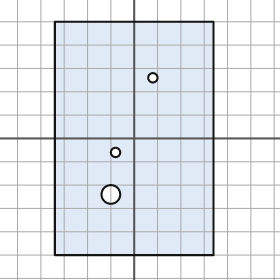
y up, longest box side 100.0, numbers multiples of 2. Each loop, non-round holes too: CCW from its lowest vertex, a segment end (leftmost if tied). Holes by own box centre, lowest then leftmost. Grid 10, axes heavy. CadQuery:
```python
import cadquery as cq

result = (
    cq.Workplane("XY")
    .moveTo(-34.0, -50.0)
    .lineTo(34.0, -50.0)
    .lineTo(34.0, 50.0)
    .lineTo(-34.0, 50.0)
    .close()
    .moveTo(-10.0, -24.0)
    .circle(4.0)
    .moveTo(-8.0, -6.0)
    .circle(2.0)
    .moveTo(8.0, 26.0)
    .circle(2.0)
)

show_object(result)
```